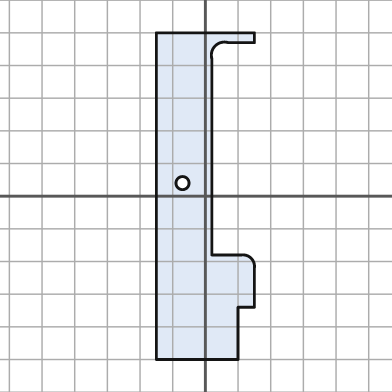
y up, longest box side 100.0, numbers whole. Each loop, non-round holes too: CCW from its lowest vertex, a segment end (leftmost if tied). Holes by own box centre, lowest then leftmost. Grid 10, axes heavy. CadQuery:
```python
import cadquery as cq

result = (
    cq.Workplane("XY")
    .moveTo(-15.0, -50.0)
    .lineTo(10.0, -50.0)
    .lineTo(10.0, -34.0)
    .lineTo(15.0, -34.0)
    .lineTo(15.0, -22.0)
    .threePointArc((14.0, -19.0), (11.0, -18.0))
    .lineTo(2.0, -18.0)
    .lineTo(2.0, 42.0)
    .threePointArc((3.0, 46.0), (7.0, 47.0))
    .lineTo(15.0, 47.0)
    .lineTo(15.0, 50.0)
    .lineTo(-15.0, 50.0)
    .close()
    .moveTo(-7.0, 4.0)
    .circle(2.0)
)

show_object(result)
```